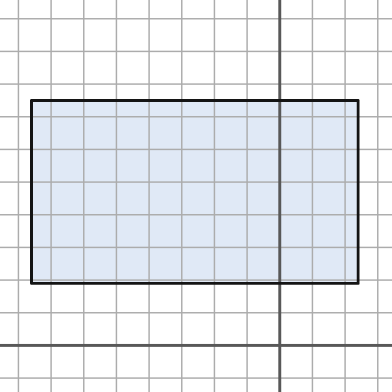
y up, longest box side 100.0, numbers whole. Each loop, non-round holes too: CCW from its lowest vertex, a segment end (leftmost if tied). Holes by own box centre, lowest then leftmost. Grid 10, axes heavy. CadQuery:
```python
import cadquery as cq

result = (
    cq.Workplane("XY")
    .moveTo(-76.0, 19.0)
    .lineTo(24.0, 19.0)
    .lineTo(24.0, 75.0)
    .lineTo(-76.0, 75.0)
    .close()
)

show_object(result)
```